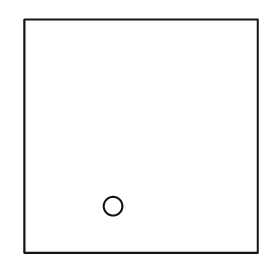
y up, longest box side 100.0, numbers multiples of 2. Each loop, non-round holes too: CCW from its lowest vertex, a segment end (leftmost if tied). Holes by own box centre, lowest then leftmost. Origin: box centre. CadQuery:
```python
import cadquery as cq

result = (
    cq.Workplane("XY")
    .moveTo(-50.0, -50.0)
    .lineTo(50.0, -50.0)
    .lineTo(50.0, 50.0)
    .lineTo(-50.0, 50.0)
    .close()
    .moveTo(-12.0, -30.0)
    .circle(4.0)
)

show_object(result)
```